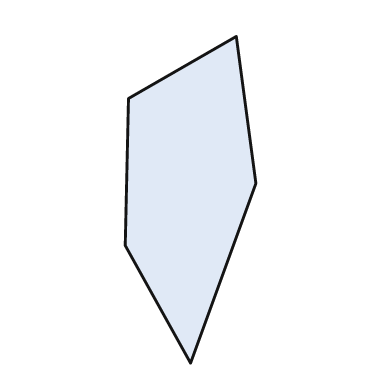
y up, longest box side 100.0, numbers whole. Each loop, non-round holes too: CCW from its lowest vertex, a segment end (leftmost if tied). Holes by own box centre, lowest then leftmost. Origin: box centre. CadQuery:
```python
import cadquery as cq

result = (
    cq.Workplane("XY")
    .moveTo(0.0, -50.0)
    .lineTo(20.0, 5.0)
    .lineTo(14.0, 50.0)
    .lineTo(-19.0, 31.0)
    .lineTo(-20.0, -14.0)
    .close()
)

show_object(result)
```